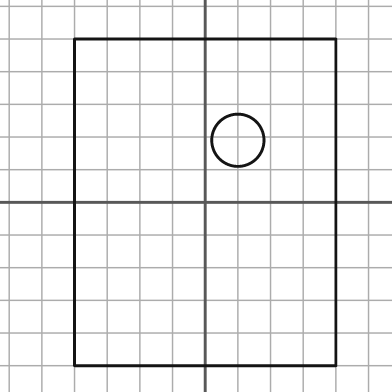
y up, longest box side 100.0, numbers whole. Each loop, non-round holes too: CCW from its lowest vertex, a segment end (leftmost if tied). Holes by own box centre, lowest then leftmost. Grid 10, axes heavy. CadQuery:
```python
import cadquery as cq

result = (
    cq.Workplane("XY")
    .moveTo(-40.0, -50.0)
    .lineTo(40.0, -50.0)
    .lineTo(40.0, 50.0)
    .lineTo(-40.0, 50.0)
    .close()
    .moveTo(10.0, 19.0)
    .circle(8.0)
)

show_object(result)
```